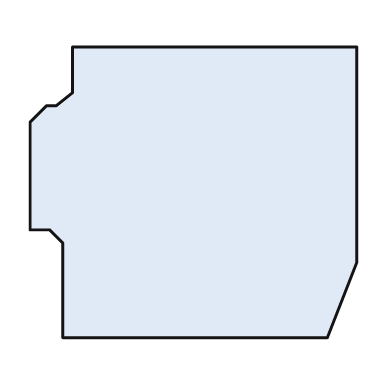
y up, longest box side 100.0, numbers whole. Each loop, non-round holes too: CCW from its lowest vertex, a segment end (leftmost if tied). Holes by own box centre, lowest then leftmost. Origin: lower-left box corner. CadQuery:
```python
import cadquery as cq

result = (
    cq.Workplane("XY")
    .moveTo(10.0, 0.0)
    .lineTo(91.0, 0.0)
    .lineTo(100.0, 23.0)
    .lineTo(100.0, 89.0)
    .lineTo(13.0, 89.0)
    .lineTo(13.0, 75.0)
    .lineTo(8.0, 71.0)
    .lineTo(5.0, 71.0)
    .lineTo(0.0, 66.0)
    .lineTo(0.0, 33.0)
    .lineTo(6.0, 33.0)
    .lineTo(10.0, 29.0)
    .close()
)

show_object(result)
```